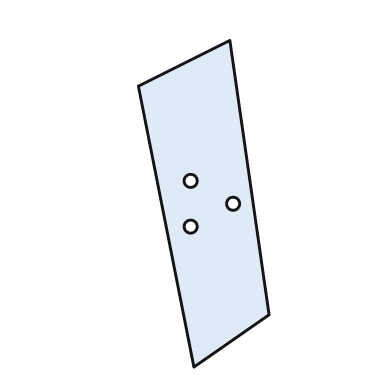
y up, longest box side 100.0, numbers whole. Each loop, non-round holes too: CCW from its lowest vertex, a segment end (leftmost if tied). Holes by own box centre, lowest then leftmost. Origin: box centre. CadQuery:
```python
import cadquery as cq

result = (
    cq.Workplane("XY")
    .moveTo(-3.0, -50.0)
    .lineTo(20.0, -34.0)
    .lineTo(8.0, 50.0)
    .lineTo(-20.0, 36.0)
    .close()
    .moveTo(-4.0, -7.0)
    .circle(2.0)
    .moveTo(9.0, 0.0)
    .circle(2.0)
    .moveTo(-4.0, 7.0)
    .circle(2.0)
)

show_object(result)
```